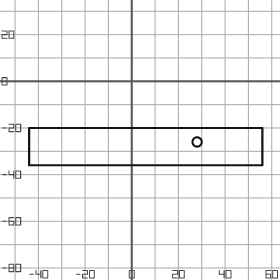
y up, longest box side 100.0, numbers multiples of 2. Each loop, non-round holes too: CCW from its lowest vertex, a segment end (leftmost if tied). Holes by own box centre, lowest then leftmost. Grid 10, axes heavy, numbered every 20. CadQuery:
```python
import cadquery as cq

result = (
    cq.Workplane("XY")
    .moveTo(-44.0, -36.0)
    .lineTo(56.0, -36.0)
    .lineTo(56.0, -20.0)
    .lineTo(-44.0, -20.0)
    .close()
    .moveTo(28.0, -26.0)
    .circle(2.0)
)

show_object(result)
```